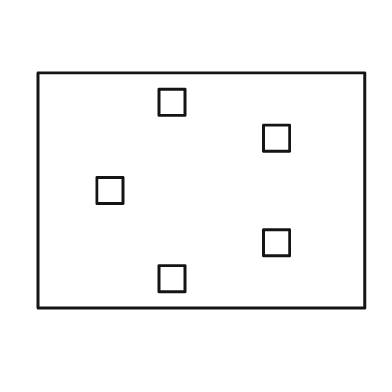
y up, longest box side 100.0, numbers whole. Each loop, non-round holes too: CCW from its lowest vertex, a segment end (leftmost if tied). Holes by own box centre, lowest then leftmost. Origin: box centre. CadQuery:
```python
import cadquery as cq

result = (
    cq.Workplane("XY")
    .moveTo(-50.0, -36.0)
    .lineTo(50.0, -36.0)
    .lineTo(50.0, 36.0)
    .lineTo(-50.0, 36.0)
    .close()
    .moveTo(-13.0, -31.0)
    .lineTo(-5.0, -31.0)
    .lineTo(-5.0, -23.0)
    .lineTo(-13.0, -23.0)
    .close()
    .moveTo(19.0, -20.0)
    .lineTo(27.0, -20.0)
    .lineTo(27.0, -12.0)
    .lineTo(19.0, -12.0)
    .close()
    .moveTo(-32.0, -4.0)
    .lineTo(-24.0, -4.0)
    .lineTo(-24.0, 4.0)
    .lineTo(-32.0, 4.0)
    .close()
    .moveTo(19.0, 12.0)
    .lineTo(27.0, 12.0)
    .lineTo(27.0, 20.0)
    .lineTo(19.0, 20.0)
    .close()
    .moveTo(-13.0, 23.0)
    .lineTo(-5.0, 23.0)
    .lineTo(-5.0, 31.0)
    .lineTo(-13.0, 31.0)
    .close()
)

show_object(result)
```